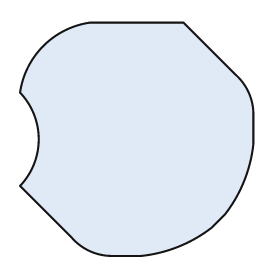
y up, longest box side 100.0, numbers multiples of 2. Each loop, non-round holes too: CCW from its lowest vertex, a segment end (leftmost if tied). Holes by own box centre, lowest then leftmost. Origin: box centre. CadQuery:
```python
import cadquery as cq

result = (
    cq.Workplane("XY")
    .moveTo(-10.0, -50.0)
    .lineTo(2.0, -50.0)
    .threePointArc((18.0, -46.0), (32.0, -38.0))
    .lineTo(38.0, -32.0)
    .threePointArc((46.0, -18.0), (50.0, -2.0))
    .lineTo(50.0, 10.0)
    .threePointArc((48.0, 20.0), (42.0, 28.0))
    .lineTo(20.0, 50.0)
    .lineTo(-20.0, 50.0)
    .threePointArc((-40.0, 40.0), (-50.0, 20.0))
    .threePointArc((-42.0, 0.0), (-50.0, -20.0))
    .lineTo(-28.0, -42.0)
    .threePointArc((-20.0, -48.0), (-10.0, -50.0))
    .close()
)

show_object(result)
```